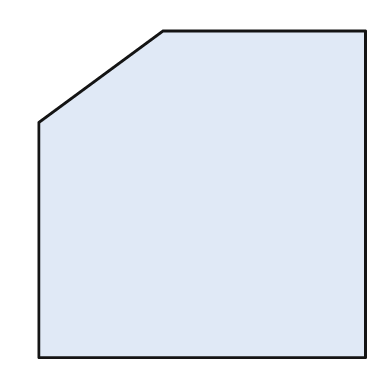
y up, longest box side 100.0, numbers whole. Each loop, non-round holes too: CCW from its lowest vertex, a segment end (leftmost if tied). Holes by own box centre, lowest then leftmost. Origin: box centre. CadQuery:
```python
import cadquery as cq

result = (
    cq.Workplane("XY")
    .moveTo(-50.0, -50.0)
    .lineTo(50.0, -50.0)
    .lineTo(50.0, 50.0)
    .lineTo(-12.0, 50.0)
    .lineTo(-50.0, 22.0)
    .close()
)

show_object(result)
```